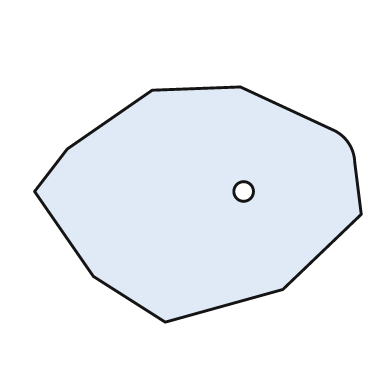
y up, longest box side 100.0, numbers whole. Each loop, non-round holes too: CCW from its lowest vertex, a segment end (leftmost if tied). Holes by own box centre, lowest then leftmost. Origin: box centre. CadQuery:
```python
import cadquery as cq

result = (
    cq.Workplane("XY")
    .moveTo(-10.0, -36.0)
    .lineTo(26.0, -26.0)
    .lineTo(50.0, -3.0)
    .lineTo(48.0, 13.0)
    .threePointArc((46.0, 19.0), (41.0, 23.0))
    .lineTo(13.0, 36.0)
    .lineTo(-14.0, 35.0)
    .lineTo(-40.0, 17.0)
    .lineTo(-50.0, 4.0)
    .lineTo(-32.0, -22.0)
    .close()
    .moveTo(14.0, 4.0)
    .circle(3.0)
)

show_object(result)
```